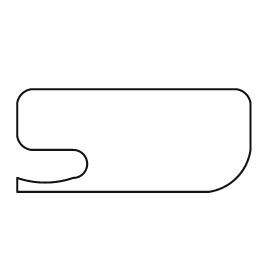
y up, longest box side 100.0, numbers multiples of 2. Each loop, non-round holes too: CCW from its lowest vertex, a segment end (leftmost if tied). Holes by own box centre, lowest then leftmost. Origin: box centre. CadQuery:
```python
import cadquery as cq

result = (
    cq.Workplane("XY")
    .moveTo(-50.0, -22.0)
    .lineTo(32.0, -22.0)
    .threePointArc((44.0, -16.0), (50.0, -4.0))
    .lineTo(50.0, 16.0)
    .threePointArc((48.0, 20.0), (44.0, 22.0))
    .lineTo(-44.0, 22.0)
    .threePointArc((-48.0, 20.0), (-50.0, 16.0))
    .lineTo(-50.0, 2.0)
    .threePointArc((-48.0, -2.0), (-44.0, -4.0))
    .lineTo(-26.0, -4.0)
    .threePointArc((-20.0, -10.0), (-26.0, -16.0))
    .threePointArc((-38.0, -18.0), (-50.0, -16.0))
    .close()
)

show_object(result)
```